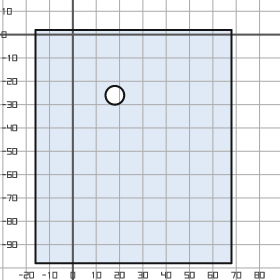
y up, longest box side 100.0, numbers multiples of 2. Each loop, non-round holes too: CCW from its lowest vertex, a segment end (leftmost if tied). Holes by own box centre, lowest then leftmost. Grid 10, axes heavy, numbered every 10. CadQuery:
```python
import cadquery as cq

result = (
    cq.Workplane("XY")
    .moveTo(-16.0, -98.0)
    .lineTo(68.0, -98.0)
    .lineTo(68.0, 2.0)
    .lineTo(-16.0, 2.0)
    .close()
    .moveTo(18.0, -26.0)
    .circle(4.0)
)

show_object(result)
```